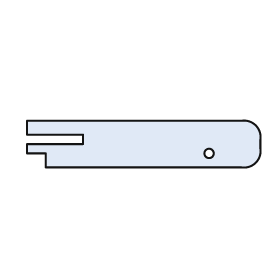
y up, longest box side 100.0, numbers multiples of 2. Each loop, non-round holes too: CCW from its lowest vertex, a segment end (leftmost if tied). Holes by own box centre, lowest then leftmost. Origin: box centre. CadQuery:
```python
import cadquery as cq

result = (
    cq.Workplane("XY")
    .moveTo(-42.0, -10.0)
    .lineTo(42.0, -10.0)
    .threePointArc((48.0, -8.0), (50.0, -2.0))
    .lineTo(50.0, 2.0)
    .threePointArc((48.0, 8.0), (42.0, 10.0))
    .lineTo(-50.0, 10.0)
    .lineTo(-50.0, 4.0)
    .lineTo(-26.0, 4.0)
    .lineTo(-26.0, 0.0)
    .lineTo(-50.0, 0.0)
    .lineTo(-50.0, -4.0)
    .lineTo(-42.0, -4.0)
    .close()
    .moveTo(28.0, -4.0)
    .circle(2.0)
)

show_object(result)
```